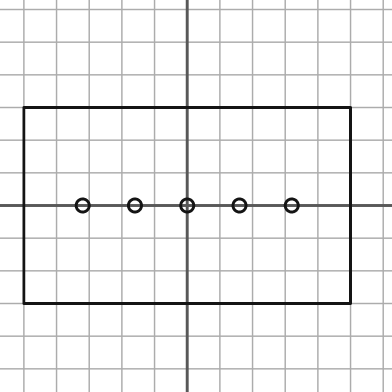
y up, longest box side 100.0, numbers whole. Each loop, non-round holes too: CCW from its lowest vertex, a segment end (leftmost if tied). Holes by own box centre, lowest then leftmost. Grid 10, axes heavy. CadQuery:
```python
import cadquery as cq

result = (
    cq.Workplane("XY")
    .moveTo(-50.0, -30.0)
    .lineTo(50.0, -30.0)
    .lineTo(50.0, 30.0)
    .lineTo(-50.0, 30.0)
    .close()
    .moveTo(-32.0, 0.0)
    .circle(2.0)
    .moveTo(-16.0, 0.0)
    .circle(2.0)
    .moveTo(0.0, 0.0)
    .circle(2.0)
    .moveTo(16.0, 0.0)
    .circle(2.0)
    .moveTo(32.0, 0.0)
    .circle(2.0)
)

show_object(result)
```